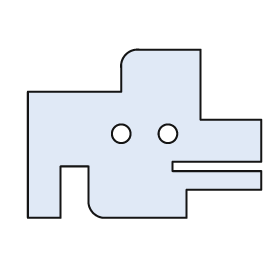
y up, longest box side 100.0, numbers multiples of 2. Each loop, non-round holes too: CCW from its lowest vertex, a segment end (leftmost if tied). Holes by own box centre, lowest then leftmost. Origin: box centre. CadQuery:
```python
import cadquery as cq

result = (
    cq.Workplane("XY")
    .moveTo(-50.0, -36.0)
    .lineTo(-36.0, -36.0)
    .lineTo(-36.0, -14.0)
    .lineTo(-24.0, -14.0)
    .lineTo(-24.0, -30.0)
    .threePointArc((-22.0, -34.0), (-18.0, -36.0))
    .lineTo(18.0, -36.0)
    .lineTo(18.0, -24.0)
    .lineTo(50.0, -24.0)
    .lineTo(50.0, -16.0)
    .lineTo(12.0, -16.0)
    .lineTo(12.0, -12.0)
    .lineTo(50.0, -12.0)
    .lineTo(50.0, 6.0)
    .lineTo(24.0, 6.0)
    .lineTo(24.0, 36.0)
    .lineTo(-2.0, 36.0)
    .threePointArc((-8.0, 34.0), (-10.0, 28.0))
    .lineTo(-10.0, 18.0)
    .lineTo(-50.0, 18.0)
    .close()
    .moveTo(-10.0, 0.0)
    .circle(4.0)
    .moveTo(10.0, 0.0)
    .circle(4.0)
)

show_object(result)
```